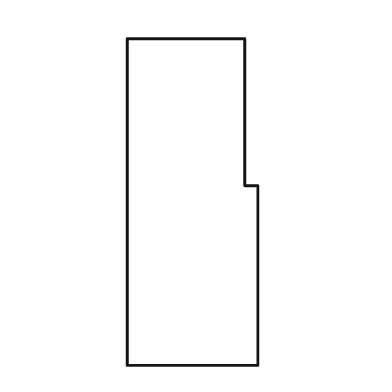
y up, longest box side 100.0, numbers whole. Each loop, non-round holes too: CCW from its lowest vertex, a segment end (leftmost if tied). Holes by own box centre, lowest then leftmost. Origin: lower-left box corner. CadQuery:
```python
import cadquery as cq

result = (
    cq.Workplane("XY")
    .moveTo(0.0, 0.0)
    .lineTo(40.0, 0.0)
    .lineTo(40.0, 55.0)
    .lineTo(36.0, 55.0)
    .lineTo(36.0, 100.0)
    .lineTo(0.0, 100.0)
    .close()
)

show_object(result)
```